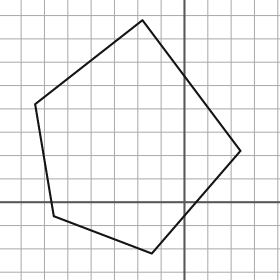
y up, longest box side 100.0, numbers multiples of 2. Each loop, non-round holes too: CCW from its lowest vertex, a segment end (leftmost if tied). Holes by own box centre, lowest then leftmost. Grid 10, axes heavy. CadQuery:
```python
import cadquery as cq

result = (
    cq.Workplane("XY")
    .moveTo(-14.0, -22.0)
    .lineTo(24.0, 22.0)
    .lineTo(-18.0, 78.0)
    .lineTo(-64.0, 42.0)
    .lineTo(-56.0, -6.0)
    .close()
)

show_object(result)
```